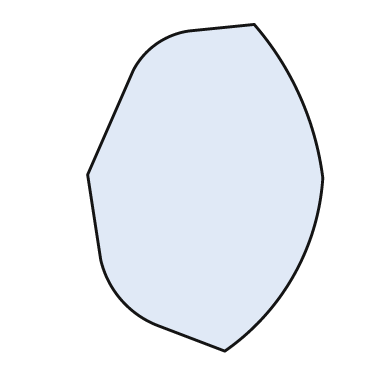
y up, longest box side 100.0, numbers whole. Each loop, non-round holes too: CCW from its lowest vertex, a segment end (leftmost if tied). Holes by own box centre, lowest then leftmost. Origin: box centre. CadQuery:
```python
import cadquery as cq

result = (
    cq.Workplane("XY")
    .moveTo(6.0, -50.0)
    .threePointArc((27.0, -27.0), (36.0, 3.0))
    .threePointArc((29.0, 28.0), (15.0, 50.0))
    .lineTo(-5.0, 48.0)
    .threePointArc((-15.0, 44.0), (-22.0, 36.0))
    .lineTo(-36.0, 4.0)
    .lineTo(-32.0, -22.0)
    .threePointArc((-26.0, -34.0), (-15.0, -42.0))
    .close()
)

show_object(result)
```